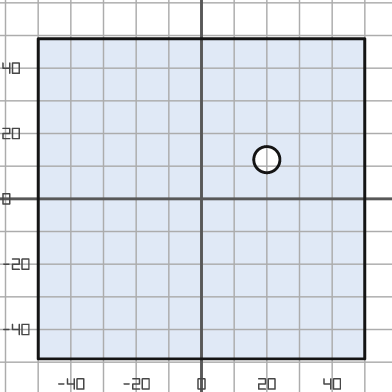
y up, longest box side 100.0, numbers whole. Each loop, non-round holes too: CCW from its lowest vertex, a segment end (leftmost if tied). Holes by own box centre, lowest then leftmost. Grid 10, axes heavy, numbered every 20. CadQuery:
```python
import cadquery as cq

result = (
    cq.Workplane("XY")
    .moveTo(-50.0, -49.0)
    .lineTo(50.0, -49.0)
    .lineTo(50.0, 49.0)
    .lineTo(-50.0, 49.0)
    .close()
    .moveTo(20.0, 12.0)
    .circle(4.0)
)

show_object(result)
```